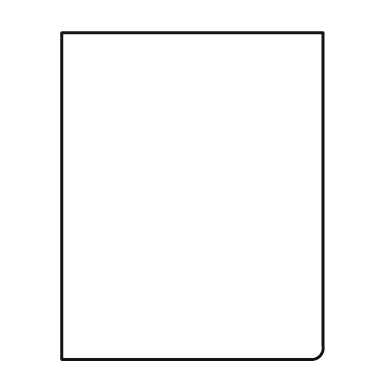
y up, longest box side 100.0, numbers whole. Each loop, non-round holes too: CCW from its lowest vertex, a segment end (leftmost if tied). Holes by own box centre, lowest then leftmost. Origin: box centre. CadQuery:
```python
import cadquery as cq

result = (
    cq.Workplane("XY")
    .moveTo(-40.0, -50.0)
    .lineTo(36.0, -50.0)
    .threePointArc((39.0, -49.0), (40.0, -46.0))
    .lineTo(40.0, 50.0)
    .lineTo(-40.0, 50.0)
    .close()
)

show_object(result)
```